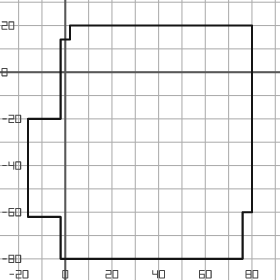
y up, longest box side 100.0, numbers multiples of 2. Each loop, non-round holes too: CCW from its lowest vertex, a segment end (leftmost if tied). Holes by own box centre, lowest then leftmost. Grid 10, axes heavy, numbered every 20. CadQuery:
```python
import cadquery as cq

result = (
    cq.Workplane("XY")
    .moveTo(-2.0, -80.0)
    .lineTo(76.0, -80.0)
    .lineTo(76.0, -60.0)
    .lineTo(80.0, -60.0)
    .lineTo(80.0, 20.0)
    .lineTo(2.0, 20.0)
    .lineTo(2.0, 14.0)
    .lineTo(-2.0, 14.0)
    .lineTo(-2.0, -20.0)
    .lineTo(-16.0, -20.0)
    .lineTo(-16.0, -62.0)
    .lineTo(-2.0, -62.0)
    .close()
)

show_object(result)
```